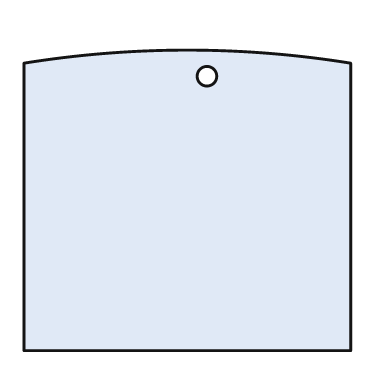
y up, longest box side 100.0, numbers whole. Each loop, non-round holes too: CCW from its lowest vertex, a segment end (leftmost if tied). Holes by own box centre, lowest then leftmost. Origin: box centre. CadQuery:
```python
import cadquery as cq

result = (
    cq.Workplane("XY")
    .moveTo(-50.0, -46.0)
    .lineTo(50.0, -46.0)
    .lineTo(50.0, 42.0)
    .threePointArc((0.0, 46.0), (-50.0, 42.0))
    .close()
    .moveTo(6.0, 38.0)
    .circle(3.0)
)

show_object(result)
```